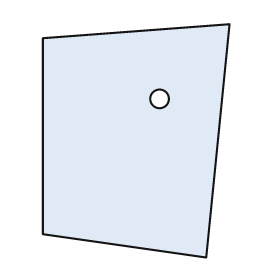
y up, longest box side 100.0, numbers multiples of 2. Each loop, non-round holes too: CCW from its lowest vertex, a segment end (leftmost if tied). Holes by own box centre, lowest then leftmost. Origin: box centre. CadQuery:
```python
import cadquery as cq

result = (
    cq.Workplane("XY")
    .moveTo(30.0, -50.0)
    .lineTo(40.0, 50.0)
    .lineTo(-40.0, 44.0)
    .lineTo(-40.0, -40.0)
    .close()
    .moveTo(10.0, 18.0)
    .circle(4.0)
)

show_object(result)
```